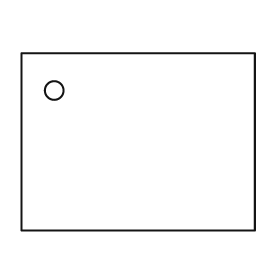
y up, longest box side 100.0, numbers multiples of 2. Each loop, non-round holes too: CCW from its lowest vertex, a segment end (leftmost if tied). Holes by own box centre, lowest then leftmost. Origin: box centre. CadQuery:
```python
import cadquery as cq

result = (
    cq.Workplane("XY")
    .moveTo(-50.0, -38.0)
    .lineTo(50.0, -38.0)
    .lineTo(50.0, 38.0)
    .lineTo(-50.0, 38.0)
    .close()
    .moveTo(-36.0, 22.0)
    .circle(4.0)
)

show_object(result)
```